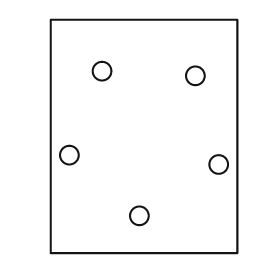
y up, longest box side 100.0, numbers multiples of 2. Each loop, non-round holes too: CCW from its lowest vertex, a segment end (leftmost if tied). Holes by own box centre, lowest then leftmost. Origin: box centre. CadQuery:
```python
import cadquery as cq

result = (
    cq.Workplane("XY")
    .moveTo(-40.0, -50.0)
    .lineTo(40.0, -50.0)
    .lineTo(40.0, 50.0)
    .lineTo(-40.0, 50.0)
    .close()
    .moveTo(-2.0, -34.0)
    .circle(4.0)
    .moveTo(32.0, -12.0)
    .circle(4.0)
    .moveTo(-32.0, -8.0)
    .circle(4.0)
    .moveTo(22.0, 26.0)
    .circle(4.0)
    .moveTo(-18.0, 28.0)
    .circle(4.0)
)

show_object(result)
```